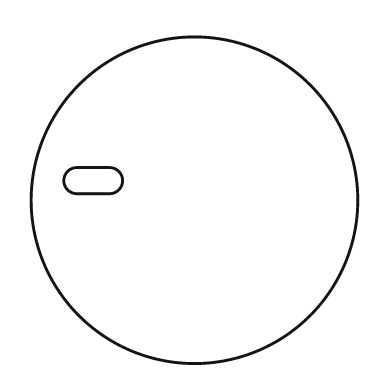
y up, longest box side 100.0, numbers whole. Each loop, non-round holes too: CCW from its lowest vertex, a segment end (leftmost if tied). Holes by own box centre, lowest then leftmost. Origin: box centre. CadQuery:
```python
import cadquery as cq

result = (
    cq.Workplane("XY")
    .moveTo(0.0, 0.0)
    .circle(50.0)
    .moveTo(-36.0, 2.0)
    .lineTo(-26.0, 2.0)
    .threePointArc((-22.0, 6.0), (-26.0, 10.0))
    .lineTo(-36.0, 10.0)
    .threePointArc((-40.0, 6.0), (-36.0, 2.0))
    .close()
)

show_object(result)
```